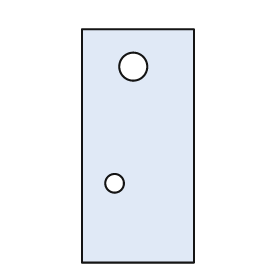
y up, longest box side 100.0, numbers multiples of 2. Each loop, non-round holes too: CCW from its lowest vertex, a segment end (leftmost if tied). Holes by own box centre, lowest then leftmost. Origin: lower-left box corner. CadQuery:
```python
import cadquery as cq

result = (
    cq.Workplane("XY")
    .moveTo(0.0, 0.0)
    .lineTo(48.0, 0.0)
    .lineTo(48.0, 100.0)
    .lineTo(0.0, 100.0)
    .close()
    .moveTo(14.0, 34.0)
    .circle(4.0)
    .moveTo(22.0, 84.0)
    .circle(6.0)
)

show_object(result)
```